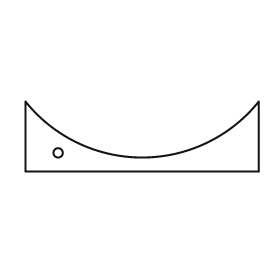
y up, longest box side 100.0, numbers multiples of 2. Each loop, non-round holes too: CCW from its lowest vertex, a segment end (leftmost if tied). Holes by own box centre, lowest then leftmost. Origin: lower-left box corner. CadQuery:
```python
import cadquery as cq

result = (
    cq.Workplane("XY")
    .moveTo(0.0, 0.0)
    .lineTo(100.0, 0.0)
    .lineTo(100.0, 30.0)
    .threePointArc((50.0, 6.0), (0.0, 30.0))
    .close()
    .moveTo(14.0, 8.0)
    .circle(2.0)
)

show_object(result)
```